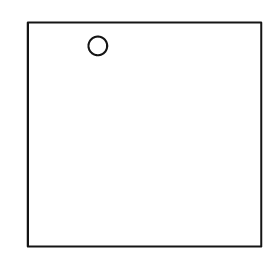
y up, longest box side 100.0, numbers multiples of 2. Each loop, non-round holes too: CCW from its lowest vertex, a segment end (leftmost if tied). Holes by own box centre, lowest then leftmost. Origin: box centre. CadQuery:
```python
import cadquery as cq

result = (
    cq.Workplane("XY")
    .moveTo(-50.0, -48.0)
    .lineTo(50.0, -48.0)
    .lineTo(50.0, 48.0)
    .lineTo(-50.0, 48.0)
    .close()
    .moveTo(-20.0, 38.0)
    .circle(4.0)
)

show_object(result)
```